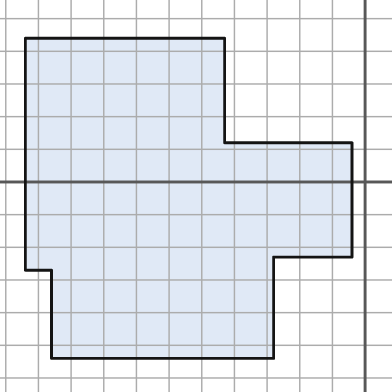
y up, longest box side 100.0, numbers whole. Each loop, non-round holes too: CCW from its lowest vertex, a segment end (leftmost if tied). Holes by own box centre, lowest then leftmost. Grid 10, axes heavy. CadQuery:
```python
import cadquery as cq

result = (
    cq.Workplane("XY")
    .moveTo(-96.0, -54.0)
    .lineTo(-28.0, -54.0)
    .lineTo(-28.0, -23.0)
    .lineTo(-4.0, -23.0)
    .lineTo(-4.0, 12.0)
    .lineTo(-43.0, 12.0)
    .lineTo(-43.0, 44.0)
    .lineTo(-104.0, 44.0)
    .lineTo(-104.0, -27.0)
    .lineTo(-96.0, -27.0)
    .close()
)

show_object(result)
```